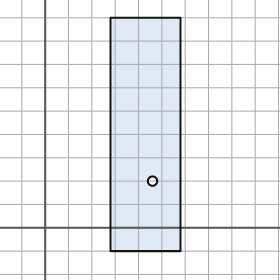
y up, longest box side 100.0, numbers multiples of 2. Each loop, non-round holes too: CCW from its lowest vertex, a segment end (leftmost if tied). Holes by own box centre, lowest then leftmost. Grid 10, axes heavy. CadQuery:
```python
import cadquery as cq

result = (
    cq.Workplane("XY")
    .moveTo(28.0, -10.0)
    .lineTo(58.0, -10.0)
    .lineTo(58.0, 90.0)
    .lineTo(28.0, 90.0)
    .close()
    .moveTo(46.0, 20.0)
    .circle(2.0)
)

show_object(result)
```